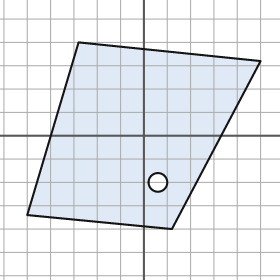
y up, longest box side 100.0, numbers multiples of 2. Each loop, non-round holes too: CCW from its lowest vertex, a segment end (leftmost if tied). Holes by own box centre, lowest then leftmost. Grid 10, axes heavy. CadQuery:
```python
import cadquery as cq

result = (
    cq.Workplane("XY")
    .moveTo(12.0, -40.0)
    .lineTo(50.0, 32.0)
    .lineTo(-28.0, 40.0)
    .lineTo(-50.0, -34.0)
    .close()
    .moveTo(6.0, -20.0)
    .circle(4.0)
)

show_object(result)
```